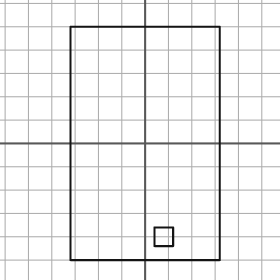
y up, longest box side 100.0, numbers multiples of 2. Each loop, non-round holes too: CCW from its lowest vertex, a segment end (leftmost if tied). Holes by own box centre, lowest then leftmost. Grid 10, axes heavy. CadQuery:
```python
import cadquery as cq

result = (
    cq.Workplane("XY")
    .moveTo(-32.0, -50.0)
    .lineTo(32.0, -50.0)
    .lineTo(32.0, 50.0)
    .lineTo(-32.0, 50.0)
    .close()
    .moveTo(4.0, -44.0)
    .lineTo(12.0, -44.0)
    .lineTo(12.0, -36.0)
    .lineTo(4.0, -36.0)
    .close()
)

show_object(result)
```